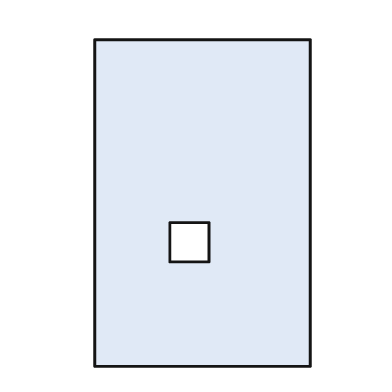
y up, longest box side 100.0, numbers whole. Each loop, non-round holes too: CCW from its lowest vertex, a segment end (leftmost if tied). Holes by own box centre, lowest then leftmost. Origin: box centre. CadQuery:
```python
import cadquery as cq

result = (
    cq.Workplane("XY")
    .moveTo(-33.0, -50.0)
    .lineTo(33.0, -50.0)
    .lineTo(33.0, 50.0)
    .lineTo(-33.0, 50.0)
    .close()
    .moveTo(-10.0, -18.0)
    .lineTo(2.0, -18.0)
    .lineTo(2.0, -6.0)
    .lineTo(-10.0, -6.0)
    .close()
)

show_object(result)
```